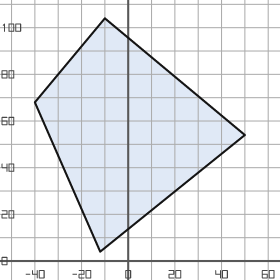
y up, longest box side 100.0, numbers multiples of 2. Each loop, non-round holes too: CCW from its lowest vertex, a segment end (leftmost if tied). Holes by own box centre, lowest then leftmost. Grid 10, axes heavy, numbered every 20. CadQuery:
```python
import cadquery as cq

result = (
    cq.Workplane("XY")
    .moveTo(-12.0, 4.0)
    .lineTo(50.0, 54.0)
    .lineTo(-10.0, 104.0)
    .lineTo(-40.0, 68.0)
    .close()
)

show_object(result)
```